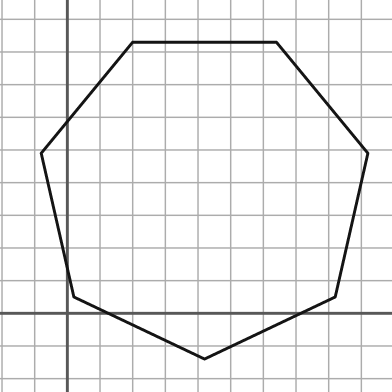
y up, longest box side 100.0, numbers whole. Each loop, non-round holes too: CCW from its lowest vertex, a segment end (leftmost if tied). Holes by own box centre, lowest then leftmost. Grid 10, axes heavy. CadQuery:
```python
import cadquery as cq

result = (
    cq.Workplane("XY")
    .moveTo(42.0, -14.0)
    .lineTo(82.0, 5.0)
    .lineTo(92.0, 49.0)
    .lineTo(64.0, 83.0)
    .lineTo(20.0, 83.0)
    .lineTo(-8.0, 49.0)
    .lineTo(2.0, 5.0)
    .close()
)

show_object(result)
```